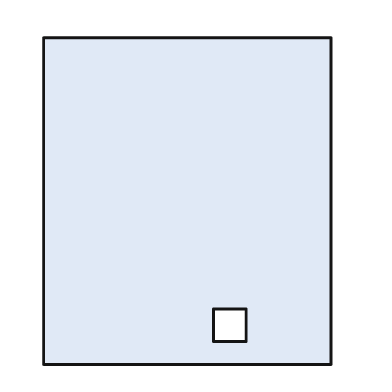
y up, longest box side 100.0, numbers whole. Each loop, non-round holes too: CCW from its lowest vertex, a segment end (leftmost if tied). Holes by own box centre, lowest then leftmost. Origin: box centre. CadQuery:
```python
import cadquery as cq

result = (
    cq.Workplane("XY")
    .moveTo(-44.0, -50.0)
    .lineTo(44.0, -50.0)
    .lineTo(44.0, 50.0)
    .lineTo(-44.0, 50.0)
    .close()
    .moveTo(8.0, -43.0)
    .lineTo(18.0, -43.0)
    .lineTo(18.0, -33.0)
    .lineTo(8.0, -33.0)
    .close()
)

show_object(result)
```